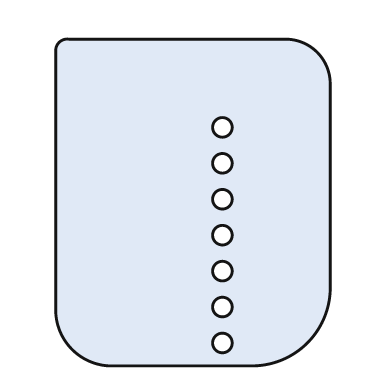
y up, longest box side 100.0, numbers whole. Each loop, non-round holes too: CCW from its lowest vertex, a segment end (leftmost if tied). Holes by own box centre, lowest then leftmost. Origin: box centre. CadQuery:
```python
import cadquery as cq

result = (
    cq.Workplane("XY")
    .moveTo(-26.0, -50.0)
    .lineTo(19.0, -50.0)
    .threePointArc((35.0, -43.0), (42.0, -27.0))
    .lineTo(42.0, 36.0)
    .threePointArc((38.0, 46.0), (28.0, 50.0))
    .lineTo(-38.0, 50.0)
    .threePointArc((-41.0, 49.0), (-42.0, 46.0))
    .lineTo(-42.0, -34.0)
    .threePointArc((-37.0, -45.0), (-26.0, -50.0))
    .close()
    .moveTo(9.0, -43.0)
    .circle(3.0)
    .moveTo(9.0, -32.0)
    .circle(3.0)
    .moveTo(9.0, -21.0)
    .circle(3.0)
    .moveTo(9.0, -10.0)
    .circle(3.0)
    .moveTo(9.0, 1.0)
    .circle(3.0)
    .moveTo(9.0, 12.0)
    .circle(3.0)
    .moveTo(9.0, 23.0)
    .circle(3.0)
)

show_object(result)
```